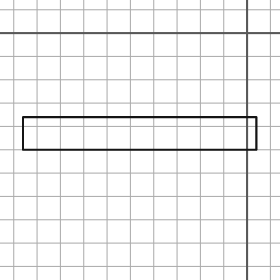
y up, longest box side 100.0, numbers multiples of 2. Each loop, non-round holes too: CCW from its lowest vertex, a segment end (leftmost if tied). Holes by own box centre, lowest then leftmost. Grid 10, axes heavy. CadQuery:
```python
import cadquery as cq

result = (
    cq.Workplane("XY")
    .moveTo(-96.0, -50.0)
    .lineTo(4.0, -50.0)
    .lineTo(4.0, -36.0)
    .lineTo(-96.0, -36.0)
    .close()
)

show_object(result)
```